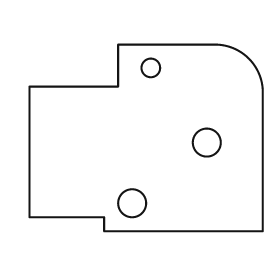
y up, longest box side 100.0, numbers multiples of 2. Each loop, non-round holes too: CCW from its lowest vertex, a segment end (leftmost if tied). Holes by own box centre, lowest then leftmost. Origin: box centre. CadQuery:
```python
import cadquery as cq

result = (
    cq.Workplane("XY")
    .moveTo(-18.0, -40.0)
    .lineTo(50.0, -40.0)
    .lineTo(50.0, 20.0)
    .threePointArc((44.0, 34.0), (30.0, 40.0))
    .lineTo(-12.0, 40.0)
    .lineTo(-12.0, 22.0)
    .lineTo(-50.0, 22.0)
    .lineTo(-50.0, -34.0)
    .lineTo(-18.0, -34.0)
    .close()
    .moveTo(-6.0, -28.0)
    .circle(6.0)
    .moveTo(26.0, -2.0)
    .circle(6.0)
    .moveTo(2.0, 30.0)
    .circle(4.0)
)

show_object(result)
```